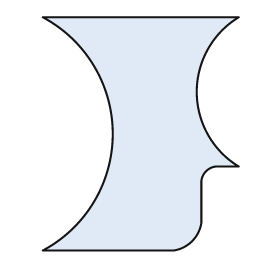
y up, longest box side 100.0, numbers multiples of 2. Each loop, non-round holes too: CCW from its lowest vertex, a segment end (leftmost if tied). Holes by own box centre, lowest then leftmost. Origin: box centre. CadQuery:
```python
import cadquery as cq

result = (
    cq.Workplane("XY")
    .moveTo(-42.0, -50.0)
    .lineTo(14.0, -50.0)
    .threePointArc((22.0, -46.0), (26.0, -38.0))
    .lineTo(26.0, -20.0)
    .threePointArc((28.0, -16.0), (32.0, -14.0))
    .lineTo(42.0, -14.0)
    .threePointArc((24.0, 18.0), (42.0, 50.0))
    .lineTo(-42.0, 50.0)
    .threePointArc((-12.0, 0.0), (-42.0, -50.0))
    .close()
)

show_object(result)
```